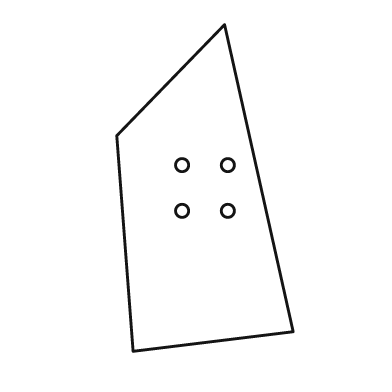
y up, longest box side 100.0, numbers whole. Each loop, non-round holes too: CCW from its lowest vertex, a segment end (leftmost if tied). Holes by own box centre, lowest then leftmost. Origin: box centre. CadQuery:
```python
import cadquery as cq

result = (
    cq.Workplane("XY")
    .moveTo(-22.0, -50.0)
    .lineTo(27.0, -44.0)
    .lineTo(6.0, 50.0)
    .lineTo(-27.0, 16.0)
    .close()
    .moveTo(-7.0, -7.0)
    .circle(2.0)
    .moveTo(7.0, -7.0)
    .circle(2.0)
    .moveTo(-7.0, 7.0)
    .circle(2.0)
    .moveTo(7.0, 7.0)
    .circle(2.0)
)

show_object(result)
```